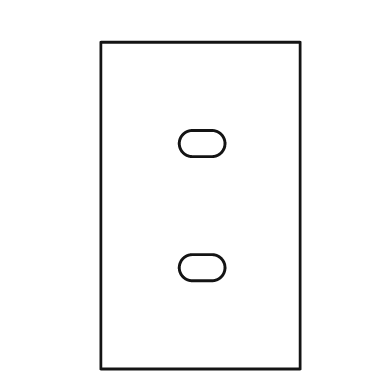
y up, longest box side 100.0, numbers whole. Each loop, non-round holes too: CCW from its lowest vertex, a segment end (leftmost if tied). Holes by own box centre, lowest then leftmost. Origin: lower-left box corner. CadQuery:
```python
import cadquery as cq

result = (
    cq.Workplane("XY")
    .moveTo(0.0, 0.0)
    .lineTo(61.0, 0.0)
    .lineTo(61.0, 100.0)
    .lineTo(0.0, 100.0)
    .close()
    .moveTo(28.0, 27.0)
    .lineTo(34.0, 27.0)
    .threePointArc((38.0, 31.0), (34.0, 35.0))
    .lineTo(28.0, 35.0)
    .threePointArc((24.0, 31.0), (28.0, 27.0))
    .close()
    .moveTo(28.0, 65.0)
    .lineTo(34.0, 65.0)
    .threePointArc((38.0, 69.0), (34.0, 73.0))
    .lineTo(28.0, 73.0)
    .threePointArc((24.0, 69.0), (28.0, 65.0))
    .close()
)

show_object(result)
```